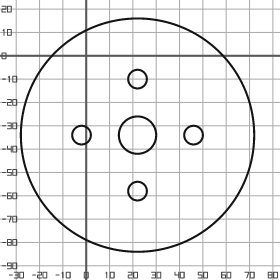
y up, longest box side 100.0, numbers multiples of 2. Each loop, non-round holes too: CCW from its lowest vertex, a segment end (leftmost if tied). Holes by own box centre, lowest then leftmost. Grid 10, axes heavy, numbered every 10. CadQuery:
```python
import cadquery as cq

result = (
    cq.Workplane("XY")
    .moveTo(22.0, -34.0)
    .circle(50.0)
    .moveTo(22.0, -58.0)
    .circle(4.0)
    .moveTo(-2.0, -34.0)
    .circle(4.0)
    .moveTo(22.0, -34.0)
    .circle(8.0)
    .moveTo(46.0, -34.0)
    .circle(4.0)
    .moveTo(22.0, -10.0)
    .circle(4.0)
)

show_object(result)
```